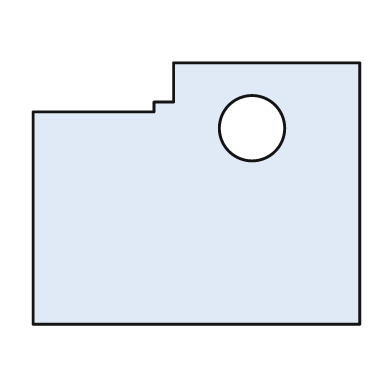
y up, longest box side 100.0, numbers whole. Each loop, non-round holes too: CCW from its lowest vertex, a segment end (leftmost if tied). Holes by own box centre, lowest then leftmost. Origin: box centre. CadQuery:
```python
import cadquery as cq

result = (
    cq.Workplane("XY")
    .moveTo(-50.0, -40.0)
    .lineTo(50.0, -40.0)
    .lineTo(50.0, 40.0)
    .lineTo(-7.0, 40.0)
    .lineTo(-7.0, 28.0)
    .lineTo(-13.0, 28.0)
    .lineTo(-13.0, 25.0)
    .lineTo(-50.0, 25.0)
    .close()
    .moveTo(17.0, 20.0)
    .circle(10.0)
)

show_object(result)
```